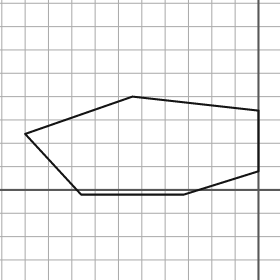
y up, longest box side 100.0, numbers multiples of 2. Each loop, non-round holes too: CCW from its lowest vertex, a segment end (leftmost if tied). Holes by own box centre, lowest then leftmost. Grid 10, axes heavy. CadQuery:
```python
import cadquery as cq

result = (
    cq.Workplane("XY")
    .moveTo(-76.0, -2.0)
    .lineTo(-32.0, -2.0)
    .lineTo(0.0, 8.0)
    .lineTo(0.0, 34.0)
    .lineTo(-54.0, 40.0)
    .lineTo(-100.0, 24.0)
    .close()
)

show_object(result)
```